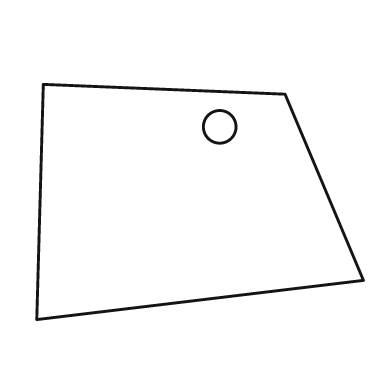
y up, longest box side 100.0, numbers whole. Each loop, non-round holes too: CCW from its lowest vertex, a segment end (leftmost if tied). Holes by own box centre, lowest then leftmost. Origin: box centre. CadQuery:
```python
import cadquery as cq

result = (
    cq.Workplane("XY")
    .moveTo(-50.0, -36.0)
    .lineTo(50.0, -24.0)
    .lineTo(26.0, 33.0)
    .lineTo(-48.0, 36.0)
    .close()
    .moveTo(6.0, 23.0)
    .circle(5.0)
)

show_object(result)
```